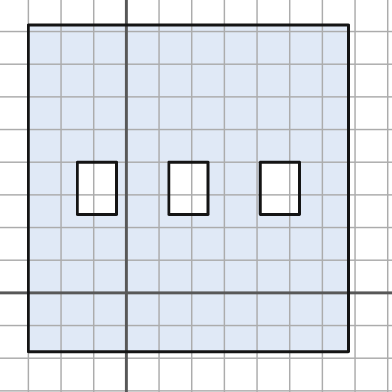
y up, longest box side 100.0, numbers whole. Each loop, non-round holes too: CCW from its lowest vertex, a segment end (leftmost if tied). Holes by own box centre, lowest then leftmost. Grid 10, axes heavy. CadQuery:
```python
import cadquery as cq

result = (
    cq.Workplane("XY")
    .moveTo(-30.0, -18.0)
    .lineTo(68.0, -18.0)
    .lineTo(68.0, 82.0)
    .lineTo(-30.0, 82.0)
    .close()
    .moveTo(-15.0, 24.0)
    .lineTo(-3.0, 24.0)
    .lineTo(-3.0, 40.0)
    .lineTo(-15.0, 40.0)
    .close()
    .moveTo(13.0, 24.0)
    .lineTo(25.0, 24.0)
    .lineTo(25.0, 40.0)
    .lineTo(13.0, 40.0)
    .close()
    .moveTo(41.0, 24.0)
    .lineTo(53.0, 24.0)
    .lineTo(53.0, 40.0)
    .lineTo(41.0, 40.0)
    .close()
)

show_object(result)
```